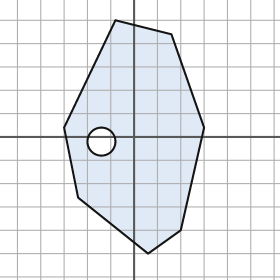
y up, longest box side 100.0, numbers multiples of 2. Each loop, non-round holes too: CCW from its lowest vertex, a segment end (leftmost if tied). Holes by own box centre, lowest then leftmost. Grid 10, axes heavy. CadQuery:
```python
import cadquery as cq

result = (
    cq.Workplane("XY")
    .moveTo(6.0, -50.0)
    .lineTo(20.0, -40.0)
    .lineTo(30.0, 4.0)
    .lineTo(16.0, 44.0)
    .lineTo(-8.0, 50.0)
    .lineTo(-30.0, 4.0)
    .lineTo(-24.0, -26.0)
    .close()
    .moveTo(-14.0, -2.0)
    .circle(6.0)
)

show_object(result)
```